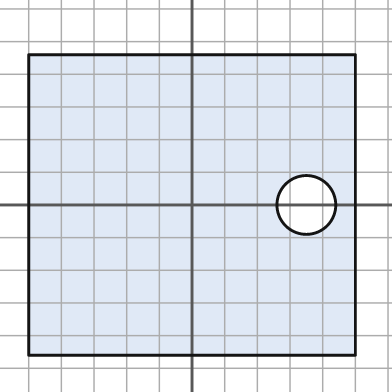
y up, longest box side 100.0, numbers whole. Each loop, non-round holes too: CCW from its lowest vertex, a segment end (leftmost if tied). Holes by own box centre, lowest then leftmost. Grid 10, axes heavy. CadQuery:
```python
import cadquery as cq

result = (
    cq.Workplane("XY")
    .moveTo(-50.0, -46.0)
    .lineTo(50.0, -46.0)
    .lineTo(50.0, 46.0)
    .lineTo(-50.0, 46.0)
    .close()
    .moveTo(35.0, 0.0)
    .circle(9.0)
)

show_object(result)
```